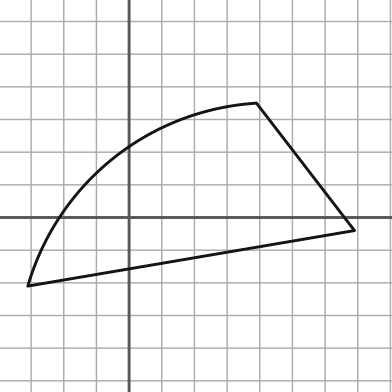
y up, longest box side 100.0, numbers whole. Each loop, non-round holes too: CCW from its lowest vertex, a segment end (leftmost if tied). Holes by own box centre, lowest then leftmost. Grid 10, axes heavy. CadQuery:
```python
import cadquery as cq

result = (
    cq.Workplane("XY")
    .moveTo(-31.0, -21.0)
    .lineTo(69.0, -4.0)
    .lineTo(39.0, 35.0)
    .threePointArc((-5.0, 18.0), (-31.0, -21.0))
    .close()
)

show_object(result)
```